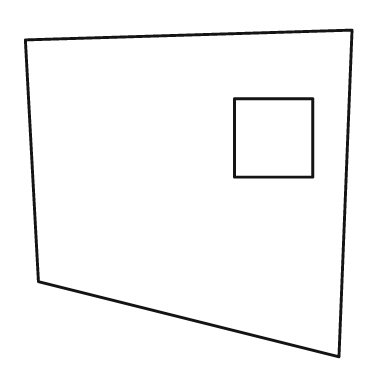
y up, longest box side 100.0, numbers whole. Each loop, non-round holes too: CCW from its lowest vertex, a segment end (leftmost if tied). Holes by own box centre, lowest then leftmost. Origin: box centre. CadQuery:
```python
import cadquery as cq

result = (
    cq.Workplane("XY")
    .moveTo(46.0, -50.0)
    .lineTo(50.0, 50.0)
    .lineTo(-50.0, 47.0)
    .lineTo(-46.0, -27.0)
    .close()
    .moveTo(14.0, 5.0)
    .lineTo(38.0, 5.0)
    .lineTo(38.0, 29.0)
    .lineTo(14.0, 29.0)
    .close()
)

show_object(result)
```